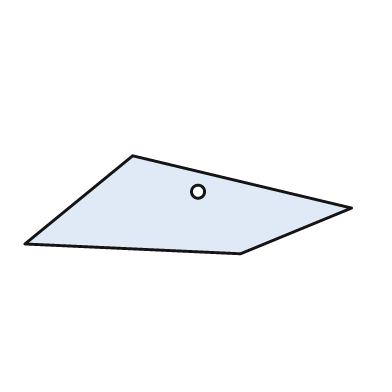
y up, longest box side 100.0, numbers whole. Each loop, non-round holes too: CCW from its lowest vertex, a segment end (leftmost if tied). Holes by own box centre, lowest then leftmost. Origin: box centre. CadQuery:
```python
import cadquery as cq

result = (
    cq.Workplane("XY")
    .moveTo(16.0, -15.0)
    .lineTo(50.0, -1.0)
    .lineTo(-17.0, 15.0)
    .lineTo(-50.0, -12.0)
    .close()
    .moveTo(3.0, 4.0)
    .circle(2.0)
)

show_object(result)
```